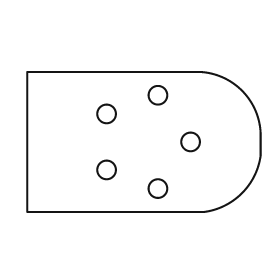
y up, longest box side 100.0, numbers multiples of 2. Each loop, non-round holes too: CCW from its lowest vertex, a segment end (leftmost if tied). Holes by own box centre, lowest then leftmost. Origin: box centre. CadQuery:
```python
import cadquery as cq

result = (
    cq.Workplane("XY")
    .moveTo(-50.0, -30.0)
    .lineTo(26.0, -30.0)
    .threePointArc((42.0, -22.0), (50.0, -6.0))
    .lineTo(50.0, 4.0)
    .threePointArc((42.0, 22.0), (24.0, 30.0))
    .lineTo(-50.0, 30.0)
    .close()
    .moveTo(6.0, -20.0)
    .circle(4.0)
    .moveTo(-16.0, -12.0)
    .circle(4.0)
    .moveTo(20.0, 0.0)
    .circle(4.0)
    .moveTo(-16.0, 12.0)
    .circle(4.0)
    .moveTo(6.0, 20.0)
    .circle(4.0)
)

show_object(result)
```